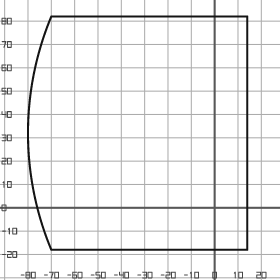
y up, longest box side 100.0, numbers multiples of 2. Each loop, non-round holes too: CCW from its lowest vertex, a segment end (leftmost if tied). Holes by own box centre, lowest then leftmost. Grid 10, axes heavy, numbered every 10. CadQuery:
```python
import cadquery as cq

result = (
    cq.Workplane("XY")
    .moveTo(-70.0, -18.0)
    .lineTo(14.0, -18.0)
    .lineTo(14.0, 82.0)
    .lineTo(-70.0, 82.0)
    .threePointArc((-80.0, 32.0), (-70.0, -18.0))
    .close()
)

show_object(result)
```